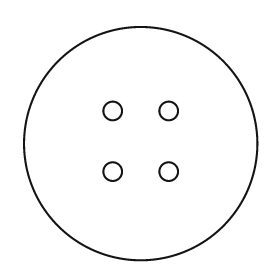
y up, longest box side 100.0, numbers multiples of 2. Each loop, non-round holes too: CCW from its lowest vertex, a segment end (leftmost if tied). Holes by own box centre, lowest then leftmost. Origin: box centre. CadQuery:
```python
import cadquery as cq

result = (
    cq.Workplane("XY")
    .moveTo(0.0, 0.0)
    .circle(50.0)
    .moveTo(-12.0, -12.0)
    .circle(4.0)
    .moveTo(12.0, -12.0)
    .circle(4.0)
    .moveTo(-12.0, 14.0)
    .circle(4.0)
    .moveTo(12.0, 14.0)
    .circle(4.0)
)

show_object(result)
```